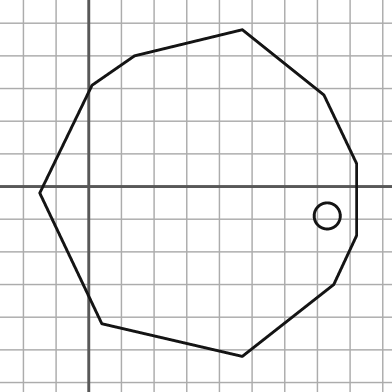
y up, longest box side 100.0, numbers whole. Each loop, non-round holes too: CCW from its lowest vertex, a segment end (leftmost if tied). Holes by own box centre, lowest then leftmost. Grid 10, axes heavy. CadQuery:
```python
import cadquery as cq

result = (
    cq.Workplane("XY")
    .moveTo(47.0, -52.0)
    .lineTo(75.0, -30.0)
    .lineTo(82.0, -15.0)
    .lineTo(82.0, 7.0)
    .lineTo(72.0, 28.0)
    .lineTo(47.0, 48.0)
    .lineTo(14.0, 40.0)
    .lineTo(1.0, 31.0)
    .lineTo(-15.0, -2.0)
    .lineTo(4.0, -42.0)
    .close()
    .moveTo(73.0, -9.0)
    .circle(4.0)
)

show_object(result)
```